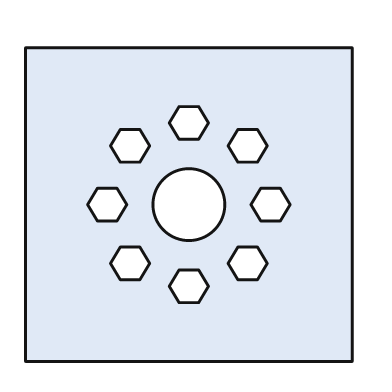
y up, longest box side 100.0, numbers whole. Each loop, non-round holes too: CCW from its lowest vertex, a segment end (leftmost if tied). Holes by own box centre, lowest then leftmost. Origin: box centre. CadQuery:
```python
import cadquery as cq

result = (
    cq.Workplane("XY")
    .moveTo(-50.0, -48.0)
    .lineTo(50.0, -48.0)
    .lineTo(50.0, 48.0)
    .lineTo(-50.0, 48.0)
    .close()
    .moveTo(-3.0, -30.0)
    .lineTo(3.0, -30.0)
    .lineTo(6.0, -25.0)
    .lineTo(3.0, -20.0)
    .lineTo(-3.0, -20.0)
    .lineTo(-6.0, -25.0)
    .close()
    .moveTo(-21.0, -23.0)
    .lineTo(-15.0, -23.0)
    .lineTo(-12.0, -18.0)
    .lineTo(-15.0, -13.0)
    .lineTo(-21.0, -13.0)
    .lineTo(-24.0, -18.0)
    .close()
    .moveTo(15.0, -23.0)
    .lineTo(21.0, -23.0)
    .lineTo(24.0, -18.0)
    .lineTo(21.0, -13.0)
    .lineTo(15.0, -13.0)
    .lineTo(12.0, -18.0)
    .close()
    .moveTo(-28.0, -5.0)
    .lineTo(-22.0, -5.0)
    .lineTo(-19.0, 0.0)
    .lineTo(-22.0, 5.0)
    .lineTo(-28.0, 5.0)
    .lineTo(-31.0, 0.0)
    .close()
    .moveTo(0.0, 0.0)
    .circle(11.0)
    .moveTo(22.0, -5.0)
    .lineTo(28.0, -5.0)
    .lineTo(31.0, 0.0)
    .lineTo(28.0, 5.0)
    .lineTo(22.0, 5.0)
    .lineTo(19.0, 0.0)
    .close()
    .moveTo(-21.0, 13.0)
    .lineTo(-15.0, 13.0)
    .lineTo(-12.0, 18.0)
    .lineTo(-15.0, 23.0)
    .lineTo(-21.0, 23.0)
    .lineTo(-24.0, 18.0)
    .close()
    .moveTo(15.0, 13.0)
    .lineTo(21.0, 13.0)
    .lineTo(24.0, 18.0)
    .lineTo(21.0, 23.0)
    .lineTo(15.0, 23.0)
    .lineTo(12.0, 18.0)
    .close()
    .moveTo(-3.0, 20.0)
    .lineTo(3.0, 20.0)
    .lineTo(6.0, 25.0)
    .lineTo(3.0, 30.0)
    .lineTo(-3.0, 30.0)
    .lineTo(-6.0, 25.0)
    .close()
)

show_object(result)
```